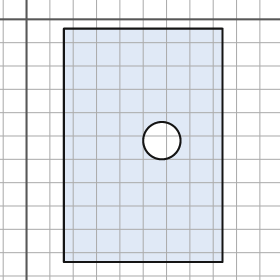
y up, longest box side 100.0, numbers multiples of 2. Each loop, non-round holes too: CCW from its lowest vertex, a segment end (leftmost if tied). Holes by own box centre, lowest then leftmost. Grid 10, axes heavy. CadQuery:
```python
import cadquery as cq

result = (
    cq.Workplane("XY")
    .moveTo(16.0, -104.0)
    .lineTo(84.0, -104.0)
    .lineTo(84.0, -4.0)
    .lineTo(16.0, -4.0)
    .close()
    .moveTo(58.0, -52.0)
    .circle(8.0)
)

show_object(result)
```